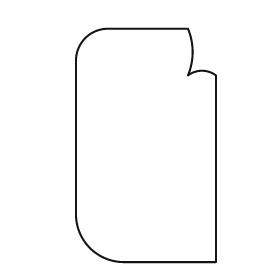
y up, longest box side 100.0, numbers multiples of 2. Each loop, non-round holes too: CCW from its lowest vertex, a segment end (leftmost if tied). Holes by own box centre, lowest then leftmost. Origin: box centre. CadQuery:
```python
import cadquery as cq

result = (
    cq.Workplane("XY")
    .moveTo(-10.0, -50.0)
    .lineTo(30.0, -50.0)
    .lineTo(30.0, 30.0)
    .threePointArc((24.0, 32.0), (18.0, 30.0))
    .threePointArc((20.0, 40.0), (18.0, 50.0))
    .lineTo(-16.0, 50.0)
    .threePointArc((-26.0, 46.0), (-30.0, 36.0))
    .lineTo(-30.0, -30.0)
    .threePointArc((-24.0, -44.0), (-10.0, -50.0))
    .close()
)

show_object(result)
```